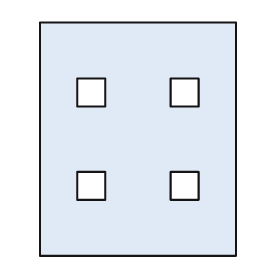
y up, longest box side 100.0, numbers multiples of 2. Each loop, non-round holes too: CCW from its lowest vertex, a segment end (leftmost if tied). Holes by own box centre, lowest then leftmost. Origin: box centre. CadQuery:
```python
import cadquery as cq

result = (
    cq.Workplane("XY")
    .moveTo(-42.0, -50.0)
    .lineTo(42.0, -50.0)
    .lineTo(42.0, 50.0)
    .lineTo(-42.0, 50.0)
    .close()
    .moveTo(-26.0, -26.0)
    .lineTo(-14.0, -26.0)
    .lineTo(-14.0, -14.0)
    .lineTo(-26.0, -14.0)
    .close()
    .moveTo(14.0, -26.0)
    .lineTo(26.0, -26.0)
    .lineTo(26.0, -14.0)
    .lineTo(14.0, -14.0)
    .close()
    .moveTo(-26.0, 14.0)
    .lineTo(-14.0, 14.0)
    .lineTo(-14.0, 26.0)
    .lineTo(-26.0, 26.0)
    .close()
    .moveTo(14.0, 14.0)
    .lineTo(26.0, 14.0)
    .lineTo(26.0, 26.0)
    .lineTo(14.0, 26.0)
    .close()
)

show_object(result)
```